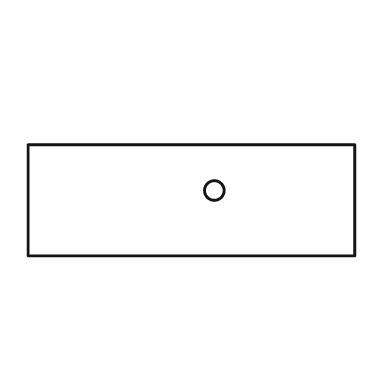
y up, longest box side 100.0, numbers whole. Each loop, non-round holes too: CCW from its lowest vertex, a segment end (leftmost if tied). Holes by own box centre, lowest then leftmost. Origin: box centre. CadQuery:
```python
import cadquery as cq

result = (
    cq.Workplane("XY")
    .moveTo(-50.0, -17.0)
    .lineTo(50.0, -17.0)
    .lineTo(50.0, 17.0)
    .lineTo(-50.0, 17.0)
    .close()
    .moveTo(7.0, 3.0)
    .circle(3.0)
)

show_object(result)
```